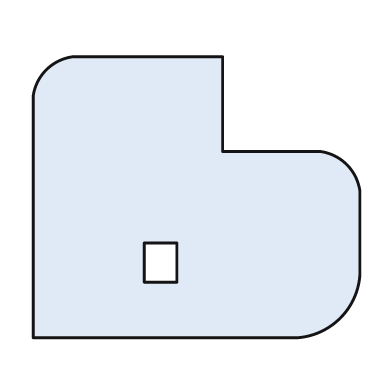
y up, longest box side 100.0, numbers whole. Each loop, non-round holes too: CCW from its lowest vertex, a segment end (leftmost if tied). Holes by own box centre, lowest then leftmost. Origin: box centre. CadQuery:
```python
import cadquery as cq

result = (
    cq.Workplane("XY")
    .moveTo(-50.0, -43.0)
    .lineTo(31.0, -43.0)
    .threePointArc((44.0, -37.0), (50.0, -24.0))
    .lineTo(50.0, 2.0)
    .threePointArc((46.0, 10.0), (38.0, 14.0))
    .lineTo(8.0, 14.0)
    .lineTo(8.0, 43.0)
    .lineTo(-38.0, 43.0)
    .threePointArc((-46.0, 39.0), (-50.0, 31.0))
    .close()
    .moveTo(-16.0, -26.0)
    .lineTo(-6.0, -26.0)
    .lineTo(-6.0, -14.0)
    .lineTo(-16.0, -14.0)
    .close()
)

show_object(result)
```